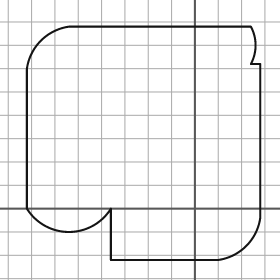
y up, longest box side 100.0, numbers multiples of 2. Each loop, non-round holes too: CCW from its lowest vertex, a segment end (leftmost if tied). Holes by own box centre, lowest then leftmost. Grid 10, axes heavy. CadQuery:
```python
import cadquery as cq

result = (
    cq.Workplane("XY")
    .moveTo(-36.0, -22.0)
    .lineTo(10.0, -22.0)
    .threePointArc((22.0, -16.0), (28.0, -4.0))
    .lineTo(28.0, 62.0)
    .lineTo(24.0, 62.0)
    .threePointArc((26.0, 70.0), (24.0, 78.0))
    .lineTo(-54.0, 78.0)
    .threePointArc((-66.0, 72.0), (-72.0, 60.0))
    .lineTo(-72.0, 0.0)
    .threePointArc((-54.0, -10.0), (-36.0, 0.0))
    .close()
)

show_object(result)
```